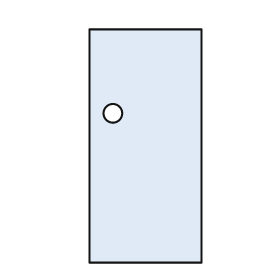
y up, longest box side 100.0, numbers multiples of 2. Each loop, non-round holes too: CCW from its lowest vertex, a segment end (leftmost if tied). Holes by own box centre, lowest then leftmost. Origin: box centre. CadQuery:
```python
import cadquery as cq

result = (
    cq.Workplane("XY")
    .moveTo(-24.0, -50.0)
    .lineTo(24.0, -50.0)
    .lineTo(24.0, 50.0)
    .lineTo(-24.0, 50.0)
    .close()
    .moveTo(-14.0, 14.0)
    .circle(4.0)
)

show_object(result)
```